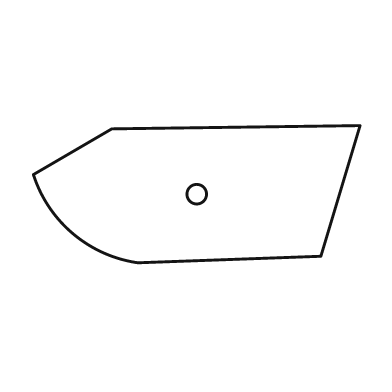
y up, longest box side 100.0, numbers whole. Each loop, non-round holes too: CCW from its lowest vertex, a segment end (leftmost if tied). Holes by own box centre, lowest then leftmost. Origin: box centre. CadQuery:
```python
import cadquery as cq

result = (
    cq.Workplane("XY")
    .moveTo(-18.0, -21.0)
    .lineTo(38.0, -19.0)
    .lineTo(50.0, 21.0)
    .lineTo(-26.0, 20.0)
    .lineTo(-50.0, 6.0)
    .threePointArc((-38.0, -12.0), (-18.0, -21.0))
    .close()
    .moveTo(0.0, 0.0)
    .circle(3.0)
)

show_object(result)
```